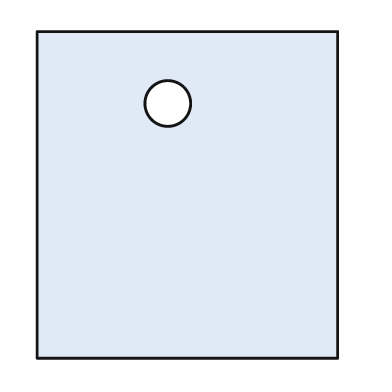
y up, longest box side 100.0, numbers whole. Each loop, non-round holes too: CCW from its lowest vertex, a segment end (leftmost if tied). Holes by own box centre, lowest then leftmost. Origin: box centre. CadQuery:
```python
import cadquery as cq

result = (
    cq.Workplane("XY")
    .moveTo(-46.0, -50.0)
    .lineTo(46.0, -50.0)
    .lineTo(46.0, 50.0)
    .lineTo(-46.0, 50.0)
    .close()
    .moveTo(-6.0, 28.0)
    .circle(7.0)
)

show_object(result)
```